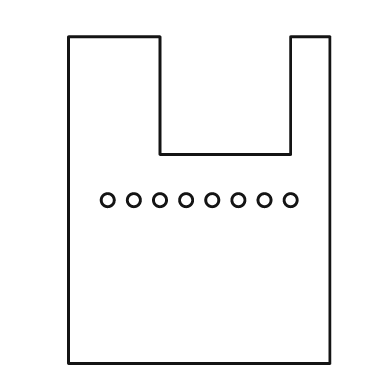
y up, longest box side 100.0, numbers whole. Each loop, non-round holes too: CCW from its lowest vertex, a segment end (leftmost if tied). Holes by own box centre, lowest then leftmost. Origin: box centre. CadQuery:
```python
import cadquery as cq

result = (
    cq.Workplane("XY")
    .moveTo(-40.0, -50.0)
    .lineTo(40.0, -50.0)
    .lineTo(40.0, 50.0)
    .lineTo(28.0, 50.0)
    .lineTo(28.0, 14.0)
    .lineTo(-12.0, 14.0)
    .lineTo(-12.0, 50.0)
    .lineTo(-40.0, 50.0)
    .close()
    .moveTo(-28.0, 0.0)
    .circle(2.0)
    .moveTo(-20.0, 0.0)
    .circle(2.0)
    .moveTo(-12.0, 0.0)
    .circle(2.0)
    .moveTo(-4.0, 0.0)
    .circle(2.0)
    .moveTo(4.0, 0.0)
    .circle(2.0)
    .moveTo(12.0, 0.0)
    .circle(2.0)
    .moveTo(20.0, 0.0)
    .circle(2.0)
    .moveTo(28.0, 0.0)
    .circle(2.0)
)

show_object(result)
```